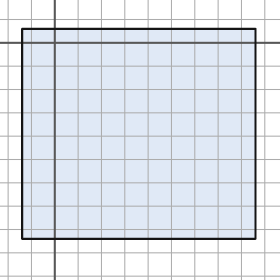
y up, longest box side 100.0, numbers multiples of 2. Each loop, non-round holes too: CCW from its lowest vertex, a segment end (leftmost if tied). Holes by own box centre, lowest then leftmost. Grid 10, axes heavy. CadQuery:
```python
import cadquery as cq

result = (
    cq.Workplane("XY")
    .moveTo(-14.0, -84.0)
    .lineTo(86.0, -84.0)
    .lineTo(86.0, 6.0)
    .lineTo(-14.0, 6.0)
    .close()
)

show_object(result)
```